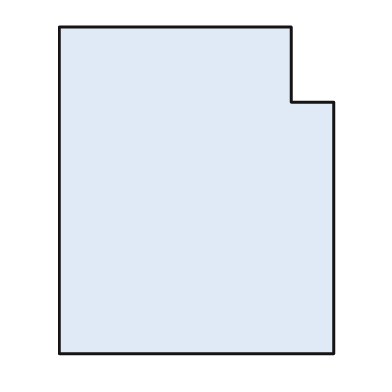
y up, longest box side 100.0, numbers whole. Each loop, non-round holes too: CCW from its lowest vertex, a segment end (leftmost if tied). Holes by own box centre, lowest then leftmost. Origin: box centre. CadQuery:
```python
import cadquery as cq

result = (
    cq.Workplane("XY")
    .moveTo(-42.0, -50.0)
    .lineTo(42.0, -50.0)
    .lineTo(42.0, 27.0)
    .lineTo(29.0, 27.0)
    .lineTo(29.0, 50.0)
    .lineTo(-42.0, 50.0)
    .close()
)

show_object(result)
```